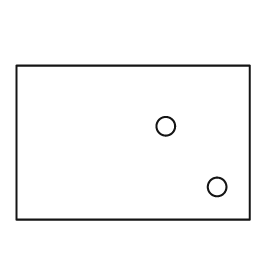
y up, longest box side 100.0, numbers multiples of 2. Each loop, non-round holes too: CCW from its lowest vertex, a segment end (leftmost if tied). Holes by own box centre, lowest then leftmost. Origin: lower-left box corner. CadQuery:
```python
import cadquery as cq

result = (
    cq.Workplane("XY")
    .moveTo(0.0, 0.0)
    .lineTo(100.0, 0.0)
    .lineTo(100.0, 66.0)
    .lineTo(0.0, 66.0)
    .close()
    .moveTo(86.0, 14.0)
    .circle(4.0)
    .moveTo(64.0, 40.0)
    .circle(4.0)
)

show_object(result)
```